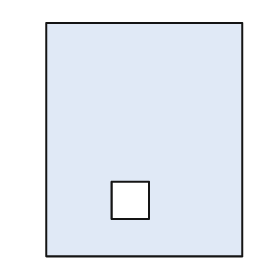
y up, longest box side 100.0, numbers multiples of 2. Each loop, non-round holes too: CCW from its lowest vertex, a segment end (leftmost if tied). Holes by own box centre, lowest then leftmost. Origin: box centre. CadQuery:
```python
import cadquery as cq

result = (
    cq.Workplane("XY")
    .moveTo(-42.0, -50.0)
    .lineTo(42.0, -50.0)
    .lineTo(42.0, 50.0)
    .lineTo(-42.0, 50.0)
    .close()
    .moveTo(-14.0, -34.0)
    .lineTo(2.0, -34.0)
    .lineTo(2.0, -18.0)
    .lineTo(-14.0, -18.0)
    .close()
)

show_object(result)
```